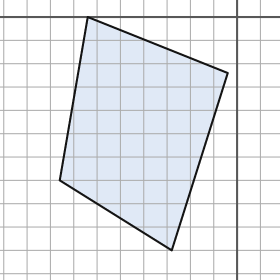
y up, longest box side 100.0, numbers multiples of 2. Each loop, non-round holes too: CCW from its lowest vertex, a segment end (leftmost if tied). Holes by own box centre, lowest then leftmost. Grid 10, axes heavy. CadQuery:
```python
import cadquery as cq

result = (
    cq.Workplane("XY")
    .moveTo(-28.0, -100.0)
    .lineTo(-4.0, -24.0)
    .lineTo(-64.0, 0.0)
    .lineTo(-76.0, -70.0)
    .close()
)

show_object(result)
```